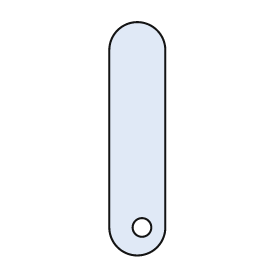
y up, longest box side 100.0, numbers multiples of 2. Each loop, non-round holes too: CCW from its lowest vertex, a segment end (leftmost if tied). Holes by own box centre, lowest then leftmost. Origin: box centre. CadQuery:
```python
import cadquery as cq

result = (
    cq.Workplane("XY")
    .moveTo(-12.0, -38.0)
    .threePointArc((0.0, -50.0), (12.0, -38.0))
    .lineTo(12.0, 38.0)
    .threePointArc((0.0, 50.0), (-12.0, 38.0))
    .close()
    .moveTo(2.0, -38.0)
    .circle(4.0)
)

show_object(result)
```